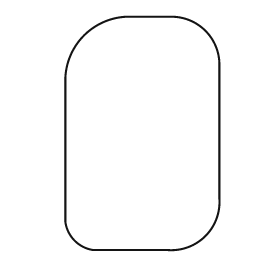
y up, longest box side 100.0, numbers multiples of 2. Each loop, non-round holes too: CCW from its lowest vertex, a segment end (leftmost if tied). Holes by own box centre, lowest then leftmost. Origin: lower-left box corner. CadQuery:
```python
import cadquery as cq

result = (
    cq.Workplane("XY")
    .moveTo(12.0, 0.0)
    .lineTo(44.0, 0.0)
    .threePointArc((60.0, 6.0), (66.0, 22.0))
    .lineTo(66.0, 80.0)
    .threePointArc((60.0, 94.0), (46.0, 100.0))
    .lineTo(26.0, 100.0)
    .threePointArc((8.0, 92.0), (0.0, 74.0))
    .lineTo(0.0, 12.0)
    .threePointArc((4.0, 4.0), (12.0, 0.0))
    .close()
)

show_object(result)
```